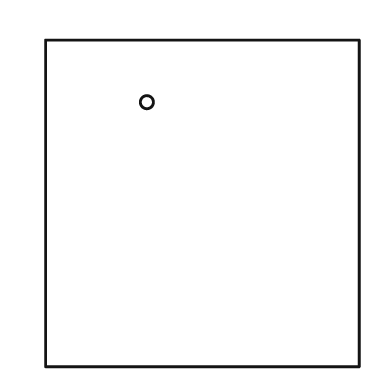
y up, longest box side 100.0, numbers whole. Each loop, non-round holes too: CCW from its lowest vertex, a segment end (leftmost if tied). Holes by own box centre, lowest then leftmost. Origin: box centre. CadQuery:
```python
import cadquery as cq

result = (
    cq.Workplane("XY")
    .moveTo(-48.0, -50.0)
    .lineTo(48.0, -50.0)
    .lineTo(48.0, 50.0)
    .lineTo(-48.0, 50.0)
    .close()
    .moveTo(-17.0, 31.0)
    .circle(2.0)
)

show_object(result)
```